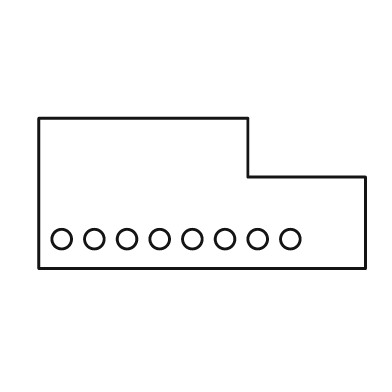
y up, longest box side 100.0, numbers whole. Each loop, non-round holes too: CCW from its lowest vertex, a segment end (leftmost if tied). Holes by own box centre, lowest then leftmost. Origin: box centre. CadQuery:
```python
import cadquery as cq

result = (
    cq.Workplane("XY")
    .moveTo(-50.0, -23.0)
    .lineTo(50.0, -23.0)
    .lineTo(50.0, 5.0)
    .lineTo(14.0, 5.0)
    .lineTo(14.0, 23.0)
    .lineTo(-50.0, 23.0)
    .close()
    .moveTo(-43.0, -14.0)
    .circle(3.0)
    .moveTo(-33.0, -14.0)
    .circle(3.0)
    .moveTo(-23.0, -14.0)
    .circle(3.0)
    .moveTo(-13.0, -14.0)
    .circle(3.0)
    .moveTo(-3.0, -14.0)
    .circle(3.0)
    .moveTo(7.0, -14.0)
    .circle(3.0)
    .moveTo(17.0, -14.0)
    .circle(3.0)
    .moveTo(27.0, -14.0)
    .circle(3.0)
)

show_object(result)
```